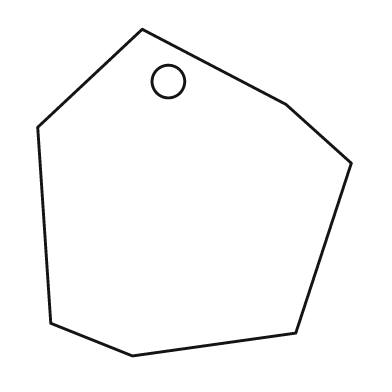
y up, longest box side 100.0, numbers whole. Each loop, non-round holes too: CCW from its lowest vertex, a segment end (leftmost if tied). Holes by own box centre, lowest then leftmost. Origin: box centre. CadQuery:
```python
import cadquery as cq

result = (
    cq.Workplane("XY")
    .moveTo(-19.0, -50.0)
    .lineTo(31.0, -43.0)
    .lineTo(48.0, 9.0)
    .lineTo(28.0, 27.0)
    .lineTo(-16.0, 50.0)
    .lineTo(-48.0, 20.0)
    .lineTo(-44.0, -40.0)
    .close()
    .moveTo(-8.0, 34.0)
    .circle(5.0)
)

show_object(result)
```